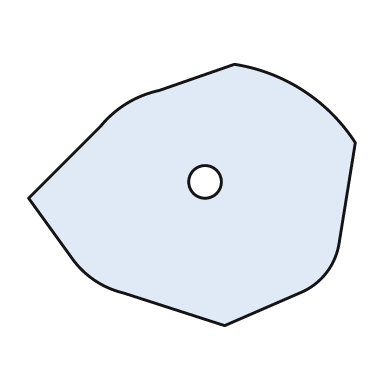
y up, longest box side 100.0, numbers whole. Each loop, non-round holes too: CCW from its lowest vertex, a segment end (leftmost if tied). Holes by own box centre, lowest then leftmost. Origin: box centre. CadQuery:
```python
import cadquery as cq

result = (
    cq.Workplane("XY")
    .moveTo(10.0, -40.0)
    .lineTo(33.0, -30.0)
    .threePointArc((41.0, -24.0), (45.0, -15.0))
    .lineTo(50.0, 16.0)
    .threePointArc((34.0, 32.0), (13.0, 40.0))
    .lineTo(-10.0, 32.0)
    .threePointArc((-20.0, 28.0), (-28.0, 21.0))
    .lineTo(-50.0, -1.0)
    .lineTo(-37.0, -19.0)
    .threePointArc((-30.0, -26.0), (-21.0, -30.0))
    .close()
    .moveTo(4.0, 4.0)
    .circle(5.0)
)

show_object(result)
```